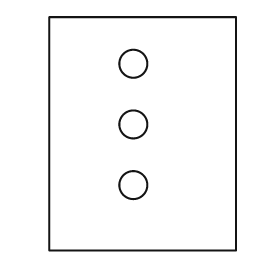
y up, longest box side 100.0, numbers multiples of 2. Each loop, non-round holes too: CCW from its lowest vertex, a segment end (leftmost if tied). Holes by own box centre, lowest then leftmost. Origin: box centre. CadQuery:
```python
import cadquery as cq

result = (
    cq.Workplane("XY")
    .moveTo(-40.0, -50.0)
    .lineTo(40.0, -50.0)
    .lineTo(40.0, 50.0)
    .lineTo(-40.0, 50.0)
    .close()
    .moveTo(-4.0, -22.0)
    .circle(6.0)
    .moveTo(-4.0, 4.0)
    .circle(6.0)
    .moveTo(-4.0, 30.0)
    .circle(6.0)
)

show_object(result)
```